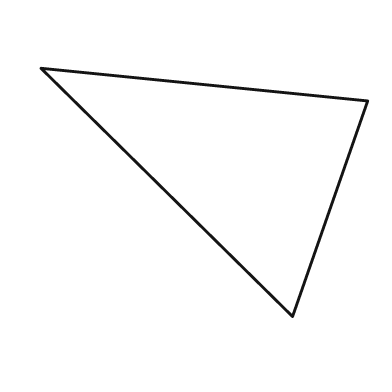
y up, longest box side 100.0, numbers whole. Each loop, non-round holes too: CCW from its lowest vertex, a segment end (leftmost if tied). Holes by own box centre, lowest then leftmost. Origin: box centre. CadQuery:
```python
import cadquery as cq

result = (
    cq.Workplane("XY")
    .moveTo(27.0, -38.0)
    .lineTo(50.0, 28.0)
    .lineTo(-50.0, 38.0)
    .close()
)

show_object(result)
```